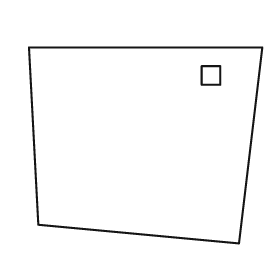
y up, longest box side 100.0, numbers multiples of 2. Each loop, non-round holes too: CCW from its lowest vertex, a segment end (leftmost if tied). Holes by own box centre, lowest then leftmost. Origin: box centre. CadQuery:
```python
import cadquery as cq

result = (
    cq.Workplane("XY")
    .moveTo(40.0, -42.0)
    .lineTo(50.0, 42.0)
    .lineTo(-50.0, 42.0)
    .lineTo(-46.0, -34.0)
    .close()
    .moveTo(24.0, 26.0)
    .lineTo(32.0, 26.0)
    .lineTo(32.0, 34.0)
    .lineTo(24.0, 34.0)
    .close()
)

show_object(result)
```